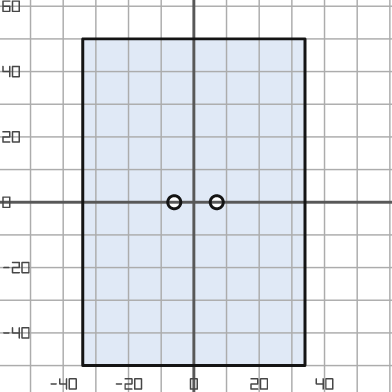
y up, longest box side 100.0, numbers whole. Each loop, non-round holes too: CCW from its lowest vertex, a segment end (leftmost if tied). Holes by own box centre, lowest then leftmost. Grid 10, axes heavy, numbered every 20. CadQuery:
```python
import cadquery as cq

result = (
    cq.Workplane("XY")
    .moveTo(-34.0, -50.0)
    .lineTo(34.0, -50.0)
    .lineTo(34.0, 50.0)
    .lineTo(-34.0, 50.0)
    .close()
    .moveTo(-6.0, 0.0)
    .circle(2.0)
    .moveTo(7.0, 0.0)
    .circle(2.0)
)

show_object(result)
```